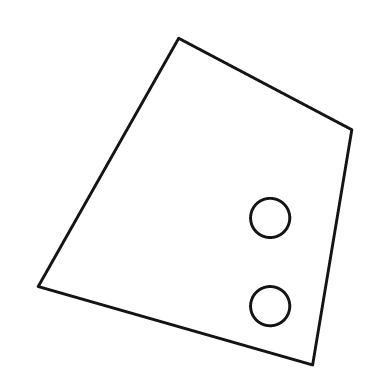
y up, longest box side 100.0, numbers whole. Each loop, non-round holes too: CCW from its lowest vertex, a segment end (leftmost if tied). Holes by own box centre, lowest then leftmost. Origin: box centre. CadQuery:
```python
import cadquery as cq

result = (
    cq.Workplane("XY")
    .moveTo(36.0, -50.0)
    .lineTo(48.0, 22.0)
    .lineTo(-5.0, 50.0)
    .lineTo(-48.0, -26.0)
    .close()
    .moveTo(23.0, -32.0)
    .circle(6.0)
    .moveTo(23.0, -5.0)
    .circle(6.0)
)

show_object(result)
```